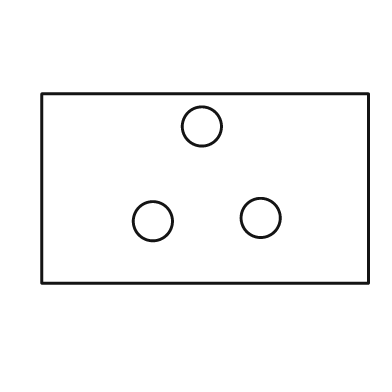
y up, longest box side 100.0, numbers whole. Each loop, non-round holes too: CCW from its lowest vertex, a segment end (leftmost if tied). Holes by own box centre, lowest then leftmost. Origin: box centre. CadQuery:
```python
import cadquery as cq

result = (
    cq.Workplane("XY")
    .moveTo(-50.0, -29.0)
    .lineTo(50.0, -29.0)
    .lineTo(50.0, 29.0)
    .lineTo(-50.0, 29.0)
    .close()
    .moveTo(-16.0, -10.0)
    .circle(6.0)
    .moveTo(17.0, -9.0)
    .circle(6.0)
    .moveTo(-1.0, 19.0)
    .circle(6.0)
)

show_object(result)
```